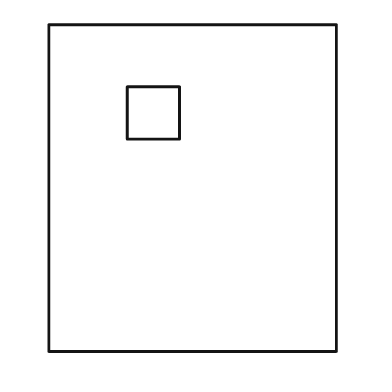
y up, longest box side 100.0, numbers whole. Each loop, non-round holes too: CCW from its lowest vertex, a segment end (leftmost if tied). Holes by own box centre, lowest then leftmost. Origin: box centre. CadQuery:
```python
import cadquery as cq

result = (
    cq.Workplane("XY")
    .moveTo(-44.0, -50.0)
    .lineTo(44.0, -50.0)
    .lineTo(44.0, 50.0)
    .lineTo(-44.0, 50.0)
    .close()
    .moveTo(-20.0, 15.0)
    .lineTo(-4.0, 15.0)
    .lineTo(-4.0, 31.0)
    .lineTo(-20.0, 31.0)
    .close()
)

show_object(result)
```